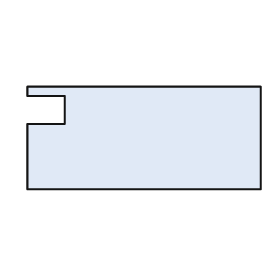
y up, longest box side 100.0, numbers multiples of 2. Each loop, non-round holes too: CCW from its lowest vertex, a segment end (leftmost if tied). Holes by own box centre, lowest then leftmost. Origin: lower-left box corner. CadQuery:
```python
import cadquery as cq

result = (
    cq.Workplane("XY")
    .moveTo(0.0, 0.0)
    .lineTo(100.0, 0.0)
    .lineTo(100.0, 44.0)
    .lineTo(0.0, 44.0)
    .lineTo(0.0, 40.0)
    .lineTo(16.0, 40.0)
    .lineTo(16.0, 28.0)
    .lineTo(0.0, 28.0)
    .close()
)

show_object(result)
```